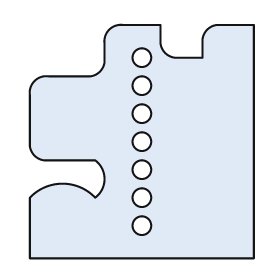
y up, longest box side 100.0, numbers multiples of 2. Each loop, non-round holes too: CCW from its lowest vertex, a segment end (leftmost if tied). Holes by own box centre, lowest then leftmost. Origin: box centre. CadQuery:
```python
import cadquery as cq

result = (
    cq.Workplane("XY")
    .moveTo(-48.0, -50.0)
    .lineTo(48.0, -50.0)
    .lineTo(48.0, 50.0)
    .lineTo(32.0, 50.0)
    .threePointArc((28.0, 48.0), (26.0, 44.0))
    .lineTo(26.0, 36.0)
    .lineTo(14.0, 36.0)
    .threePointArc((10.0, 38.0), (8.0, 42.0))
    .lineTo(8.0, 50.0)
    .lineTo(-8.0, 50.0)
    .threePointArc((-14.0, 48.0), (-16.0, 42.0))
    .lineTo(-16.0, 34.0)
    .threePointArc((-18.0, 30.0), (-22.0, 28.0))
    .lineTo(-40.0, 28.0)
    .threePointArc((-46.0, 26.0), (-48.0, 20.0))
    .lineTo(-48.0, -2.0)
    .threePointArc((-46.0, -6.0), (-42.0, -8.0))
    .lineTo(-20.0, -8.0)
    .threePointArc((-16.0, -16.0), (-20.0, -24.0))
    .threePointArc((-34.0, -18.0), (-48.0, -24.0))
    .close()
    .moveTo(0.0, -36.0)
    .circle(4.0)
    .moveTo(0.0, -24.0)
    .circle(4.0)
    .moveTo(0.0, -12.0)
    .circle(4.0)
    .moveTo(0.0, 0.0)
    .circle(4.0)
    .moveTo(0.0, 12.0)
    .circle(4.0)
    .moveTo(0.0, 24.0)
    .circle(4.0)
    .moveTo(0.0, 36.0)
    .circle(4.0)
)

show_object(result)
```